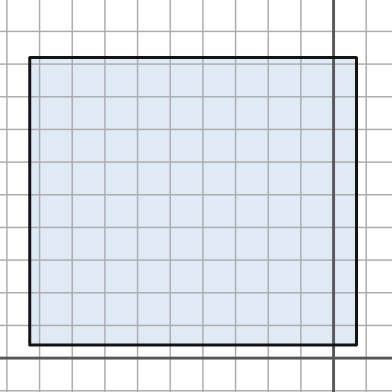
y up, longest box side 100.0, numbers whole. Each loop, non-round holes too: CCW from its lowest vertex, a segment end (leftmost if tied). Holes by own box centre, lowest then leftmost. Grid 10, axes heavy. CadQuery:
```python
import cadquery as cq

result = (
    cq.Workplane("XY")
    .moveTo(-93.0, 4.0)
    .lineTo(7.0, 4.0)
    .lineTo(7.0, 92.0)
    .lineTo(-93.0, 92.0)
    .close()
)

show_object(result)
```